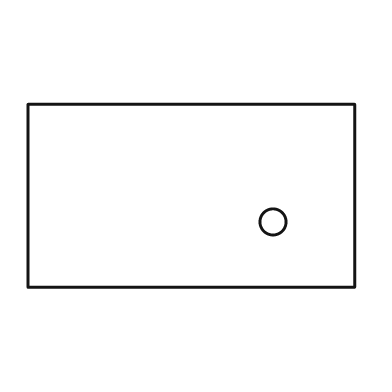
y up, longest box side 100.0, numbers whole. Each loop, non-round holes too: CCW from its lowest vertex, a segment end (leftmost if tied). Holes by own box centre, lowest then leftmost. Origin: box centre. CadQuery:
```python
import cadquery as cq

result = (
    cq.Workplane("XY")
    .moveTo(-50.0, -28.0)
    .lineTo(50.0, -28.0)
    .lineTo(50.0, 28.0)
    .lineTo(-50.0, 28.0)
    .close()
    .moveTo(25.0, -8.0)
    .circle(4.0)
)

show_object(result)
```